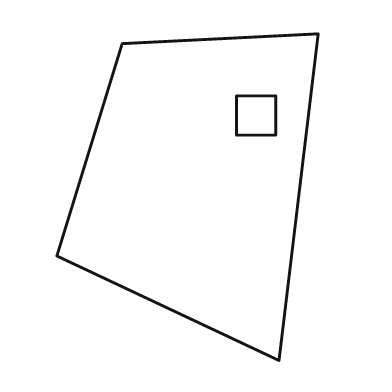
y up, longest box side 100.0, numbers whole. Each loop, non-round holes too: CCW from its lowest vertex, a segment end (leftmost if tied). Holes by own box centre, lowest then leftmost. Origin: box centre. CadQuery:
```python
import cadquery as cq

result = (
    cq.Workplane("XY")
    .moveTo(28.0, -50.0)
    .lineTo(40.0, 50.0)
    .lineTo(-20.0, 47.0)
    .lineTo(-40.0, -18.0)
    .close()
    .moveTo(15.0, 19.0)
    .lineTo(27.0, 19.0)
    .lineTo(27.0, 31.0)
    .lineTo(15.0, 31.0)
    .close()
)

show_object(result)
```